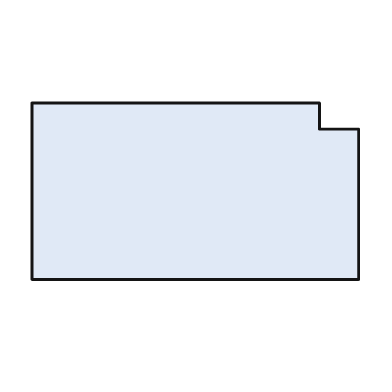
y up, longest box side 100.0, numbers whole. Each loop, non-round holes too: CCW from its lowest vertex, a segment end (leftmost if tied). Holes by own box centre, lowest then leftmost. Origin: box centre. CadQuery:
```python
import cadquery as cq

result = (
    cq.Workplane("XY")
    .moveTo(-50.0, -27.0)
    .lineTo(50.0, -27.0)
    .lineTo(50.0, 19.0)
    .lineTo(38.0, 19.0)
    .lineTo(38.0, 27.0)
    .lineTo(-50.0, 27.0)
    .close()
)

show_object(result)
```